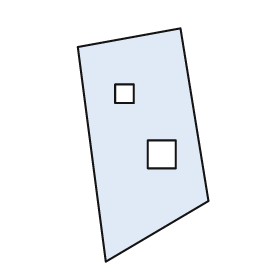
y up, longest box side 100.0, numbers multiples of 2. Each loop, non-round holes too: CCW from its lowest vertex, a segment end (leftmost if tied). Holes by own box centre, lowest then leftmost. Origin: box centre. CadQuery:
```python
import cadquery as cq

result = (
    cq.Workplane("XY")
    .moveTo(-16.0, -50.0)
    .lineTo(28.0, -24.0)
    .lineTo(16.0, 50.0)
    .lineTo(-28.0, 42.0)
    .close()
    .moveTo(2.0, -10.0)
    .lineTo(14.0, -10.0)
    .lineTo(14.0, 2.0)
    .lineTo(2.0, 2.0)
    .close()
    .moveTo(-12.0, 18.0)
    .lineTo(-4.0, 18.0)
    .lineTo(-4.0, 26.0)
    .lineTo(-12.0, 26.0)
    .close()
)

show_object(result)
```